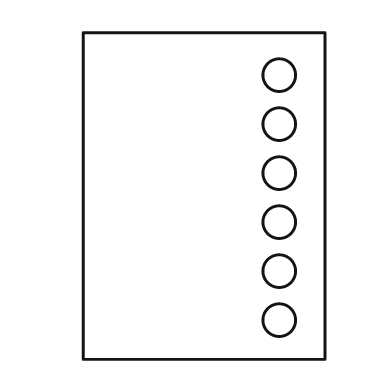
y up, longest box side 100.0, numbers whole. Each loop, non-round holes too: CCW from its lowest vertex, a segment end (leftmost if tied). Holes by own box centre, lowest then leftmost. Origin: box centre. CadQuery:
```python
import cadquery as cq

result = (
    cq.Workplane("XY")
    .moveTo(-37.0, -50.0)
    .lineTo(37.0, -50.0)
    .lineTo(37.0, 50.0)
    .lineTo(-37.0, 50.0)
    .close()
    .moveTo(23.0, -38.0)
    .circle(5.0)
    .moveTo(23.0, -23.0)
    .circle(5.0)
    .moveTo(23.0, -8.0)
    .circle(5.0)
    .moveTo(23.0, 7.0)
    .circle(5.0)
    .moveTo(23.0, 22.0)
    .circle(5.0)
    .moveTo(23.0, 37.0)
    .circle(5.0)
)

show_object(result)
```